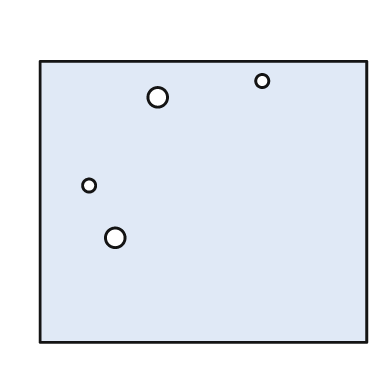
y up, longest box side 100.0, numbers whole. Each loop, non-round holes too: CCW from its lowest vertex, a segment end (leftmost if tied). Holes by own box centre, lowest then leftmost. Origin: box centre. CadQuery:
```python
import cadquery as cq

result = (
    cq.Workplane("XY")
    .moveTo(-50.0, -43.0)
    .lineTo(50.0, -43.0)
    .lineTo(50.0, 43.0)
    .lineTo(-50.0, 43.0)
    .close()
    .moveTo(-27.0, -11.0)
    .circle(3.0)
    .moveTo(-35.0, 5.0)
    .circle(2.0)
    .moveTo(-14.0, 32.0)
    .circle(3.0)
    .moveTo(18.0, 37.0)
    .circle(2.0)
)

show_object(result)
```